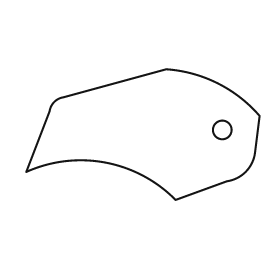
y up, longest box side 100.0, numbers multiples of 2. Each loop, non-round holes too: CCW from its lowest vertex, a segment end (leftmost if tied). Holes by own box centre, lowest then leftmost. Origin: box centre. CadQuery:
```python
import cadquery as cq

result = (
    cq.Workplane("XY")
    .moveTo(14.0, -28.0)
    .lineTo(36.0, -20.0)
    .threePointArc((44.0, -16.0), (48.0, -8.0))
    .lineTo(50.0, 8.0)
    .threePointArc((32.0, 22.0), (10.0, 28.0))
    .lineTo(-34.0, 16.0)
    .threePointArc((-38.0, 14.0), (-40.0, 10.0))
    .lineTo(-50.0, -16.0)
    .threePointArc((-16.0, -12.0), (14.0, -28.0))
    .close()
    .moveTo(34.0, 2.0)
    .circle(4.0)
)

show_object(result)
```